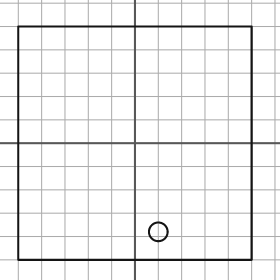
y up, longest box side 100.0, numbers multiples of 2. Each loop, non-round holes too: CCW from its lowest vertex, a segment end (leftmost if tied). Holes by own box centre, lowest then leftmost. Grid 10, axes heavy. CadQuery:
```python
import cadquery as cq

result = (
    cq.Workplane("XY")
    .moveTo(-50.0, -50.0)
    .lineTo(50.0, -50.0)
    .lineTo(50.0, 50.0)
    .lineTo(-50.0, 50.0)
    .close()
    .moveTo(10.0, -38.0)
    .circle(4.0)
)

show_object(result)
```